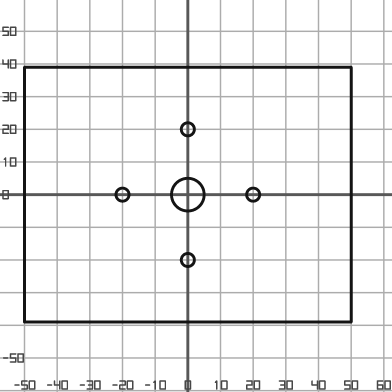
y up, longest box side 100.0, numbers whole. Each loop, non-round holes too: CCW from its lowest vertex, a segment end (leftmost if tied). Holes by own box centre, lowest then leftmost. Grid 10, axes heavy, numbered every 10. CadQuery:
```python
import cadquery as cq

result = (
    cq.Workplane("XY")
    .moveTo(-50.0, -39.0)
    .lineTo(50.0, -39.0)
    .lineTo(50.0, 39.0)
    .lineTo(-50.0, 39.0)
    .close()
    .moveTo(0.0, -20.0)
    .circle(2.0)
    .moveTo(-20.0, 0.0)
    .circle(2.0)
    .moveTo(0.0, 0.0)
    .circle(5.0)
    .moveTo(20.0, 0.0)
    .circle(2.0)
    .moveTo(0.0, 20.0)
    .circle(2.0)
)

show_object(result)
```